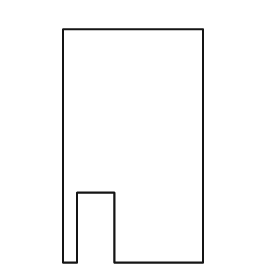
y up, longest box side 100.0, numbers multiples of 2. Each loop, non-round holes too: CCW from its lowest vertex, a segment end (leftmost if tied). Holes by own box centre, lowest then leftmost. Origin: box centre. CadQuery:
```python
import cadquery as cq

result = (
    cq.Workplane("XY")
    .moveTo(-30.0, -50.0)
    .lineTo(-24.0, -50.0)
    .lineTo(-24.0, -20.0)
    .lineTo(-8.0, -20.0)
    .lineTo(-8.0, -50.0)
    .lineTo(30.0, -50.0)
    .lineTo(30.0, 50.0)
    .lineTo(-30.0, 50.0)
    .close()
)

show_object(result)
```